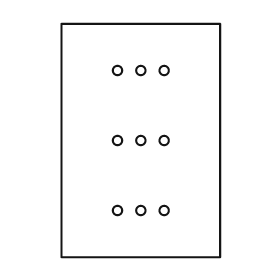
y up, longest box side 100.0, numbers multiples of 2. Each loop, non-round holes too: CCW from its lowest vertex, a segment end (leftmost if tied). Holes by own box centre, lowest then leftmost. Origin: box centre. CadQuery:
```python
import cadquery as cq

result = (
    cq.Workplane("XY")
    .moveTo(-34.0, -50.0)
    .lineTo(34.0, -50.0)
    .lineTo(34.0, 50.0)
    .lineTo(-34.0, 50.0)
    .close()
    .moveTo(-10.0, -30.0)
    .circle(2.0)
    .moveTo(0.0, -30.0)
    .circle(2.0)
    .moveTo(10.0, -30.0)
    .circle(2.0)
    .moveTo(-10.0, 0.0)
    .circle(2.0)
    .moveTo(0.0, 0.0)
    .circle(2.0)
    .moveTo(10.0, 0.0)
    .circle(2.0)
    .moveTo(-10.0, 30.0)
    .circle(2.0)
    .moveTo(0.0, 30.0)
    .circle(2.0)
    .moveTo(10.0, 30.0)
    .circle(2.0)
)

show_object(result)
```